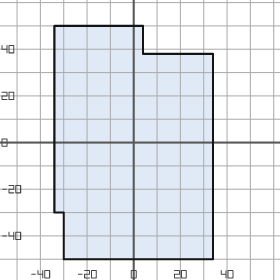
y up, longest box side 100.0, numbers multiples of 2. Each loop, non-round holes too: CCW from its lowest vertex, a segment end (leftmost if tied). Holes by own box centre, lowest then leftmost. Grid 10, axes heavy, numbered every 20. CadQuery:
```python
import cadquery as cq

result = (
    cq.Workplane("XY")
    .moveTo(-30.0, -50.0)
    .lineTo(34.0, -50.0)
    .lineTo(34.0, 38.0)
    .lineTo(4.0, 38.0)
    .lineTo(4.0, 50.0)
    .lineTo(-34.0, 50.0)
    .lineTo(-34.0, -30.0)
    .lineTo(-30.0, -30.0)
    .close()
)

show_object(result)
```